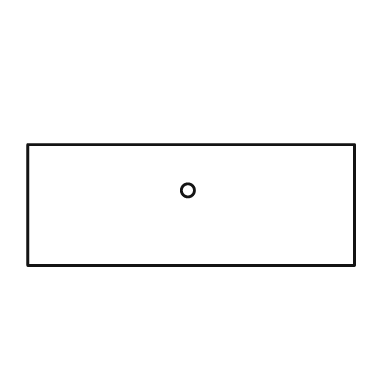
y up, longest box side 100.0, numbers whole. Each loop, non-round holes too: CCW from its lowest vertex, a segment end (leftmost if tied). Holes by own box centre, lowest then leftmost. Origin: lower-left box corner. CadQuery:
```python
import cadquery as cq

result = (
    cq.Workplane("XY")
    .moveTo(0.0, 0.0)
    .lineTo(100.0, 0.0)
    .lineTo(100.0, 37.0)
    .lineTo(0.0, 37.0)
    .close()
    .moveTo(49.0, 23.0)
    .circle(2.0)
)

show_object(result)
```